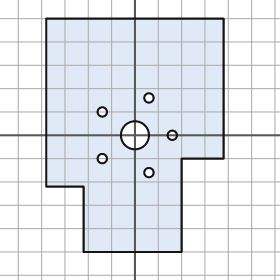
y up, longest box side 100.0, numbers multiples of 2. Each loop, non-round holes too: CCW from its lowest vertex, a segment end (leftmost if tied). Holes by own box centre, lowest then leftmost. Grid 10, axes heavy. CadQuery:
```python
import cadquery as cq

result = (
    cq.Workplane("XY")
    .moveTo(-22.0, -50.0)
    .lineTo(20.0, -50.0)
    .lineTo(20.0, -10.0)
    .lineTo(38.0, -10.0)
    .lineTo(38.0, 50.0)
    .lineTo(-38.0, 50.0)
    .lineTo(-38.0, -22.0)
    .lineTo(-22.0, -22.0)
    .close()
    .moveTo(6.0, -16.0)
    .circle(2.0)
    .moveTo(-14.0, -10.0)
    .circle(2.0)
    .moveTo(0.0, 0.0)
    .circle(6.0)
    .moveTo(16.0, 0.0)
    .circle(2.0)
    .moveTo(-14.0, 10.0)
    .circle(2.0)
    .moveTo(6.0, 16.0)
    .circle(2.0)
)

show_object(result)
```